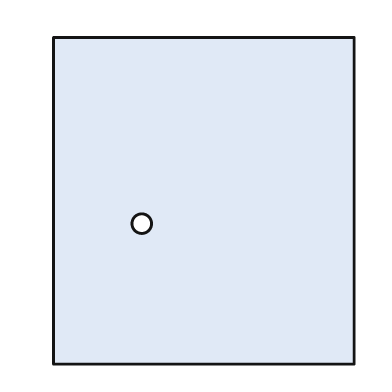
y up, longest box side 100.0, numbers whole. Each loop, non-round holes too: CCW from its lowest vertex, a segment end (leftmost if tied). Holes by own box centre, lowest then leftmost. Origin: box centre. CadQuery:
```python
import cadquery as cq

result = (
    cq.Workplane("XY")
    .moveTo(-46.0, -50.0)
    .lineTo(46.0, -50.0)
    .lineTo(46.0, 50.0)
    .lineTo(-46.0, 50.0)
    .close()
    .moveTo(-19.0, -7.0)
    .circle(3.0)
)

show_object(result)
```